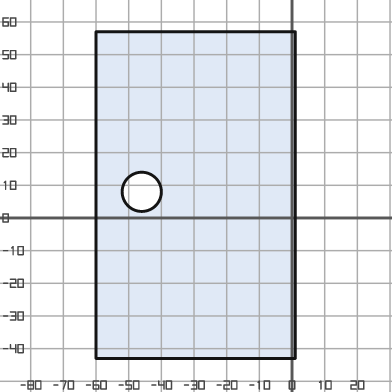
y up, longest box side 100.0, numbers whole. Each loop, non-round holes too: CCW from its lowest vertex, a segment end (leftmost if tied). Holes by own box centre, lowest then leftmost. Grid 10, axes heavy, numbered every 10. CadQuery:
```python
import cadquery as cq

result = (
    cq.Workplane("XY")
    .moveTo(-60.0, -43.0)
    .lineTo(1.0, -43.0)
    .lineTo(1.0, 57.0)
    .lineTo(-60.0, 57.0)
    .close()
    .moveTo(-46.0, 8.0)
    .circle(6.0)
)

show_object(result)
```